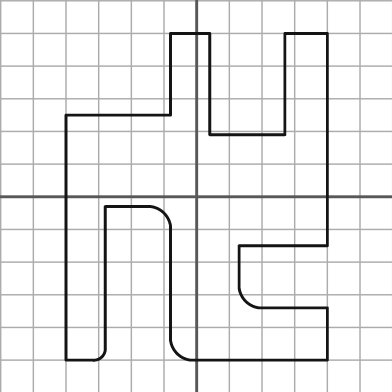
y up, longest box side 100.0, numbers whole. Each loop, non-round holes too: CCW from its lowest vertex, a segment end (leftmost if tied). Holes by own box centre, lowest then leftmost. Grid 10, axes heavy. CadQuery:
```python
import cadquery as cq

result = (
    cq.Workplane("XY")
    .moveTo(-40.0, -50.0)
    .lineTo(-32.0, -50.0)
    .threePointArc((-29.0, -49.0), (-28.0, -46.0))
    .lineTo(-28.0, -3.0)
    .lineTo(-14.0, -3.0)
    .threePointArc((-10.0, -5.0), (-8.0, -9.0))
    .lineTo(-8.0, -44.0)
    .threePointArc((-6.0, -48.0), (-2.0, -50.0))
    .lineTo(40.0, -50.0)
    .lineTo(40.0, -34.0)
    .lineTo(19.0, -34.0)
    .threePointArc((15.0, -32.0), (13.0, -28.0))
    .lineTo(13.0, -15.0)
    .lineTo(40.0, -15.0)
    .lineTo(40.0, 50.0)
    .lineTo(27.0, 50.0)
    .lineTo(27.0, 19.0)
    .lineTo(4.0, 19.0)
    .lineTo(4.0, 50.0)
    .lineTo(-8.0, 50.0)
    .lineTo(-8.0, 25.0)
    .lineTo(-40.0, 25.0)
    .close()
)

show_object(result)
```